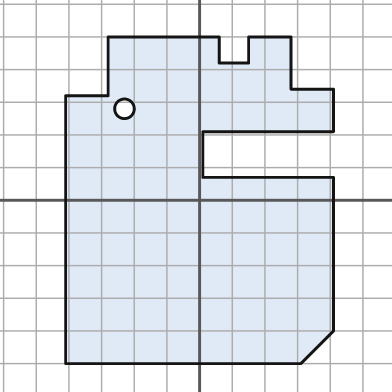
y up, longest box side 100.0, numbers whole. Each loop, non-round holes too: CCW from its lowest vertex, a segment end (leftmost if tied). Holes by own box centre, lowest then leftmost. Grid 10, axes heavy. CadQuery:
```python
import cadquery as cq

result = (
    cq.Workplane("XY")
    .moveTo(-41.0, -50.0)
    .lineTo(31.0, -50.0)
    .lineTo(41.0, -40.0)
    .lineTo(41.0, 7.0)
    .lineTo(1.0, 7.0)
    .lineTo(1.0, 21.0)
    .lineTo(41.0, 21.0)
    .lineTo(41.0, 34.0)
    .lineTo(28.0, 34.0)
    .lineTo(28.0, 50.0)
    .lineTo(15.0, 50.0)
    .lineTo(15.0, 42.0)
    .lineTo(6.0, 42.0)
    .lineTo(6.0, 50.0)
    .lineTo(-28.0, 50.0)
    .lineTo(-28.0, 32.0)
    .lineTo(-41.0, 32.0)
    .close()
    .moveTo(-23.0, 28.0)
    .circle(3.0)
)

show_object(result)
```